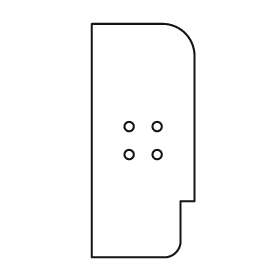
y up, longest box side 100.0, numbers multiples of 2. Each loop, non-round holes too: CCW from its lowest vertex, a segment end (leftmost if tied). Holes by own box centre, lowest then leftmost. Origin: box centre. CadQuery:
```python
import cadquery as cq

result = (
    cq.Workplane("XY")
    .moveTo(-22.0, -50.0)
    .lineTo(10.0, -50.0)
    .threePointArc((14.0, -48.0), (16.0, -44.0))
    .lineTo(16.0, -26.0)
    .lineTo(22.0, -26.0)
    .lineTo(22.0, 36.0)
    .threePointArc((18.0, 46.0), (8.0, 50.0))
    .lineTo(-22.0, 50.0)
    .close()
    .moveTo(-6.0, -6.0)
    .circle(2.0)
    .moveTo(6.0, -6.0)
    .circle(2.0)
    .moveTo(-6.0, 6.0)
    .circle(2.0)
    .moveTo(6.0, 6.0)
    .circle(2.0)
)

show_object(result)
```